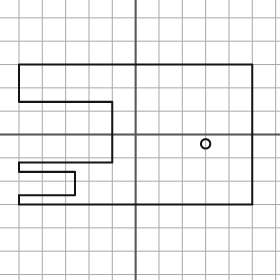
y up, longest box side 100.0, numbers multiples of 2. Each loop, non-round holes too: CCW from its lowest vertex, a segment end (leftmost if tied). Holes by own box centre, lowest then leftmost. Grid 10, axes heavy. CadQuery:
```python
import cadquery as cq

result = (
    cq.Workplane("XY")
    .moveTo(-50.0, -30.0)
    .lineTo(50.0, -30.0)
    .lineTo(50.0, 30.0)
    .lineTo(-50.0, 30.0)
    .lineTo(-50.0, 14.0)
    .lineTo(-10.0, 14.0)
    .lineTo(-10.0, -12.0)
    .lineTo(-50.0, -12.0)
    .lineTo(-50.0, -16.0)
    .lineTo(-26.0, -16.0)
    .lineTo(-26.0, -26.0)
    .lineTo(-50.0, -26.0)
    .close()
    .moveTo(30.0, -4.0)
    .circle(2.0)
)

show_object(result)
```